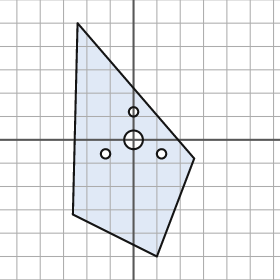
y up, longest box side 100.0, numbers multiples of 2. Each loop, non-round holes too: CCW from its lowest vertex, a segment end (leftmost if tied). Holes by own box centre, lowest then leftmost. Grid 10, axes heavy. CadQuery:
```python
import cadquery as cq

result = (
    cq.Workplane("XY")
    .moveTo(10.0, -50.0)
    .lineTo(26.0, -8.0)
    .lineTo(-24.0, 50.0)
    .lineTo(-26.0, -32.0)
    .close()
    .moveTo(-12.0, -6.0)
    .circle(2.0)
    .moveTo(12.0, -6.0)
    .circle(2.0)
    .moveTo(0.0, 0.0)
    .circle(4.0)
    .moveTo(0.0, 12.0)
    .circle(2.0)
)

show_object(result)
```